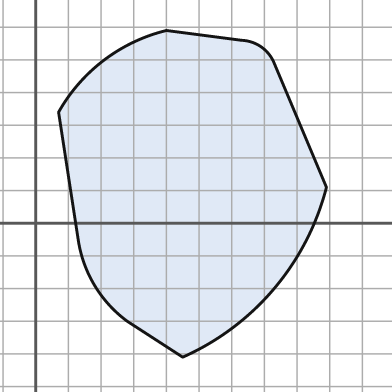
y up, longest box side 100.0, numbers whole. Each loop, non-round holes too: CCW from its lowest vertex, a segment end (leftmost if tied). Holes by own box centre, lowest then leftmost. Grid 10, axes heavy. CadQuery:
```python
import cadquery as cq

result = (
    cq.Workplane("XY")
    .moveTo(45.0, -41.0)
    .threePointArc((73.0, -20.0), (89.0, 11.0))
    .lineTo(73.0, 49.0)
    .threePointArc((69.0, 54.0), (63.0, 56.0))
    .lineTo(40.0, 59.0)
    .threePointArc((21.0, 50.0), (7.0, 34.0))
    .lineTo(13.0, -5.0)
    .threePointArc((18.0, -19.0), (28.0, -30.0))
    .close()
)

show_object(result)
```